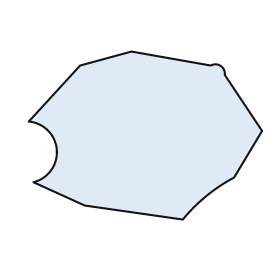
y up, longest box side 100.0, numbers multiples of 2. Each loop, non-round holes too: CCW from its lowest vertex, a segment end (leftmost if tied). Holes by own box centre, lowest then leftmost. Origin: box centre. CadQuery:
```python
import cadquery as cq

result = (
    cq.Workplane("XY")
    .moveTo(16.0, -36.0)
    .threePointArc((26.0, -26.0), (38.0, -18.0))
    .lineTo(50.0, 2.0)
    .lineTo(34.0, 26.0)
    .threePointArc((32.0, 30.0), (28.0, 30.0))
    .lineTo(-6.0, 36.0)
    .lineTo(-28.0, 30.0)
    .lineTo(-50.0, 6.0)
    .threePointArc((-38.0, -6.0), (-48.0, -20.0))
    .lineTo(-26.0, -30.0)
    .close()
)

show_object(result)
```